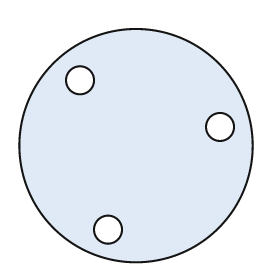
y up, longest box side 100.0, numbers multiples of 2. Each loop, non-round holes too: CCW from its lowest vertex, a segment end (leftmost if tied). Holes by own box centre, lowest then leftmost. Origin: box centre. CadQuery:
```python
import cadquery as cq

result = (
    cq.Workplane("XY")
    .moveTo(0.0, 0.0)
    .circle(50.0)
    .moveTo(-12.0, -36.0)
    .circle(6.0)
    .moveTo(36.0, 8.0)
    .circle(6.0)
    .moveTo(-24.0, 28.0)
    .circle(6.0)
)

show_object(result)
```